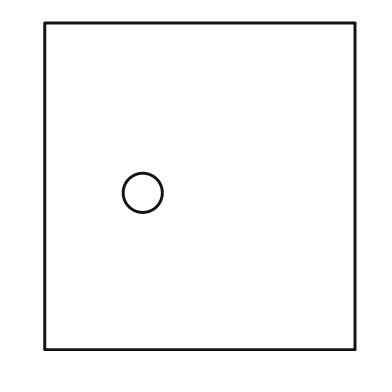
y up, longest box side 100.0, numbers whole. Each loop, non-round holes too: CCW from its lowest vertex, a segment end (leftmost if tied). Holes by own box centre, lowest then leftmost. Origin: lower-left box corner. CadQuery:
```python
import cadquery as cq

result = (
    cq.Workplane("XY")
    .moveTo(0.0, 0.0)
    .lineTo(95.0, 0.0)
    .lineTo(95.0, 100.0)
    .lineTo(0.0, 100.0)
    .close()
    .moveTo(30.0, 48.0)
    .circle(6.0)
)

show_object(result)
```